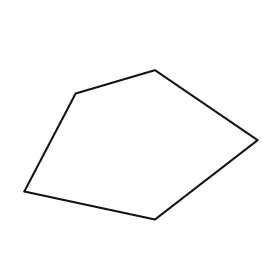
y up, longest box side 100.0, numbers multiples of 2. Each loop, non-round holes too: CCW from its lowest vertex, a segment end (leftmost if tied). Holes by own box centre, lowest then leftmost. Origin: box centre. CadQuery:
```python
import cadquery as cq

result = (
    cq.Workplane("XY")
    .moveTo(6.0, -32.0)
    .lineTo(50.0, 2.0)
    .lineTo(6.0, 32.0)
    .lineTo(-28.0, 22.0)
    .lineTo(-50.0, -20.0)
    .close()
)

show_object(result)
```